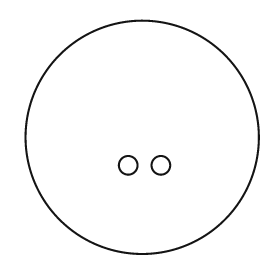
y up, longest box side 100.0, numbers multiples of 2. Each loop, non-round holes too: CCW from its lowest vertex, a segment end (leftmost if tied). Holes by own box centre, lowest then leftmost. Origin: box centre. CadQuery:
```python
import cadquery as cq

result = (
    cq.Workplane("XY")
    .moveTo(0.0, 0.0)
    .circle(50.0)
    .moveTo(-6.0, -12.0)
    .circle(4.0)
    .moveTo(8.0, -12.0)
    .circle(4.0)
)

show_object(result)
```